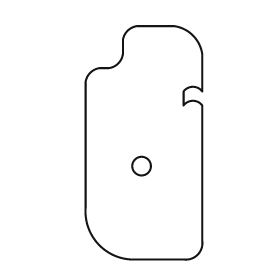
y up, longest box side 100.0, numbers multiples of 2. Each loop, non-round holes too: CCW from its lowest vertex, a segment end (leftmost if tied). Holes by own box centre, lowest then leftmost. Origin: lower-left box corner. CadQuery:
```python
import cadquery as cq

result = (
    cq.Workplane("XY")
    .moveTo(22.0, 0.0)
    .lineTo(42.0, 0.0)
    .threePointArc((48.0, 2.0), (50.0, 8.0))
    .lineTo(50.0, 66.0)
    .threePointArc((46.0, 68.0), (42.0, 66.0))
    .lineTo(42.0, 72.0)
    .threePointArc((46.0, 74.0), (50.0, 72.0))
    .lineTo(50.0, 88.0)
    .threePointArc((46.0, 96.0), (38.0, 100.0))
    .lineTo(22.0, 100.0)
    .threePointArc((18.0, 98.0), (16.0, 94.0))
    .lineTo(16.0, 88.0)
    .threePointArc((14.0, 84.0), (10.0, 82.0))
    .lineTo(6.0, 82.0)
    .threePointArc((2.0, 80.0), (0.0, 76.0))
    .lineTo(0.0, 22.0)
    .threePointArc((6.0, 6.0), (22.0, 0.0))
    .close()
    .moveTo(24.0, 40.0)
    .circle(4.0)
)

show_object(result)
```